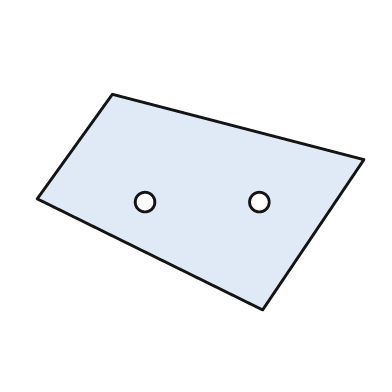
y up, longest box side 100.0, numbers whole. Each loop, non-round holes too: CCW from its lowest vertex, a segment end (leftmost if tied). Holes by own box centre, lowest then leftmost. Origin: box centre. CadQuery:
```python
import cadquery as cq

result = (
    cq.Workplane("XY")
    .moveTo(19.0, -33.0)
    .lineTo(50.0, 13.0)
    .lineTo(-27.0, 33.0)
    .lineTo(-50.0, 1.0)
    .close()
    .moveTo(-17.0, 0.0)
    .circle(3.0)
    .moveTo(18.0, 0.0)
    .circle(3.0)
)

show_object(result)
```